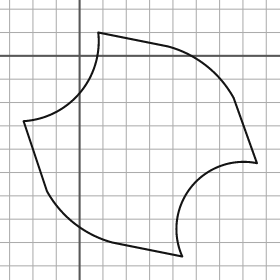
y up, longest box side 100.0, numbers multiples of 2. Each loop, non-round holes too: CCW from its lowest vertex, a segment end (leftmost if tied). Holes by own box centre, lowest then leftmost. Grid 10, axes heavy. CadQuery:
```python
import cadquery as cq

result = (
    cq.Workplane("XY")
    .moveTo(44.0, -86.0)
    .threePointArc((48.0, -56.0), (76.0, -46.0))
    .lineTo(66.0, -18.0)
    .threePointArc((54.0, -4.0), (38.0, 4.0))
    .lineTo(8.0, 10.0)
    .threePointArc((0.0, -16.0), (-24.0, -28.0))
    .lineTo(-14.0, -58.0)
    .threePointArc((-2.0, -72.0), (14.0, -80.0))
    .close()
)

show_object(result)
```